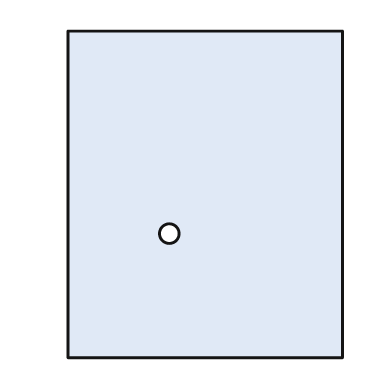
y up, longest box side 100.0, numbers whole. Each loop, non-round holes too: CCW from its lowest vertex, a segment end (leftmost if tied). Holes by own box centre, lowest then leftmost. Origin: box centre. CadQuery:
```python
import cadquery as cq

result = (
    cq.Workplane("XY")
    .moveTo(-42.0, -50.0)
    .lineTo(42.0, -50.0)
    .lineTo(42.0, 50.0)
    .lineTo(-42.0, 50.0)
    .close()
    .moveTo(-11.0, -12.0)
    .circle(3.0)
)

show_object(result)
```